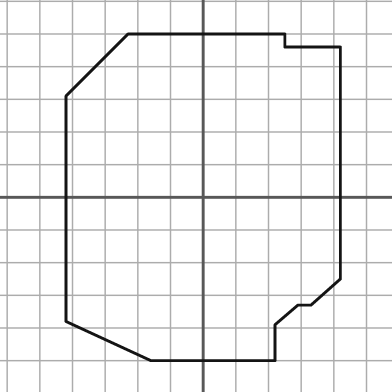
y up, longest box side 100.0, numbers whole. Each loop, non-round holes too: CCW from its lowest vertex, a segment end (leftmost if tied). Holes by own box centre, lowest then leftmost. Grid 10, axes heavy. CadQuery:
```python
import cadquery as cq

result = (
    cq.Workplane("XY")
    .moveTo(-16.0, -50.0)
    .lineTo(22.0, -50.0)
    .lineTo(22.0, -39.0)
    .lineTo(29.0, -33.0)
    .lineTo(33.0, -33.0)
    .lineTo(42.0, -25.0)
    .lineTo(42.0, 46.0)
    .lineTo(25.0, 46.0)
    .lineTo(25.0, 50.0)
    .lineTo(-23.0, 50.0)
    .lineTo(-42.0, 31.0)
    .lineTo(-42.0, -38.0)
    .close()
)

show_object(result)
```